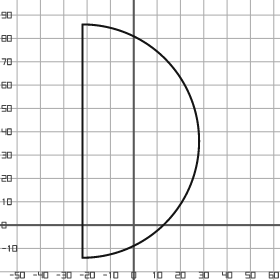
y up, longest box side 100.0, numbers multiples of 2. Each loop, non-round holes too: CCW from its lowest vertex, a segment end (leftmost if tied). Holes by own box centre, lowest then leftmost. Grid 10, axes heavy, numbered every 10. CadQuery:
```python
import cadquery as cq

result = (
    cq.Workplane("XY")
    .moveTo(-22.0, -14.0)
    .threePointArc((28.0, 36.0), (-22.0, 86.0))
    .close()
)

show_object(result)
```